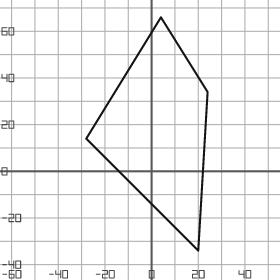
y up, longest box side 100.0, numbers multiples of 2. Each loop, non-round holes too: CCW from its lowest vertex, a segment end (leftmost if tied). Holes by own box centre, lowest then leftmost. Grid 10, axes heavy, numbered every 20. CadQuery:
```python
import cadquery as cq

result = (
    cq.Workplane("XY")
    .moveTo(20.0, -34.0)
    .lineTo(24.0, 34.0)
    .lineTo(4.0, 66.0)
    .lineTo(-28.0, 14.0)
    .close()
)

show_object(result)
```